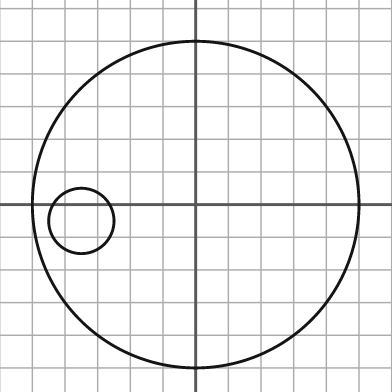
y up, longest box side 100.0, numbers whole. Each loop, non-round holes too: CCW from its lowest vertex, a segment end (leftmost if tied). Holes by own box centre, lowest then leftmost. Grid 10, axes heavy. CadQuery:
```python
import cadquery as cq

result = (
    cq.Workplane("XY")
    .moveTo(0.0, 0.0)
    .circle(50.0)
    .moveTo(-35.0, -5.0)
    .circle(10.0)
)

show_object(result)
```